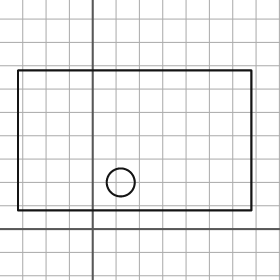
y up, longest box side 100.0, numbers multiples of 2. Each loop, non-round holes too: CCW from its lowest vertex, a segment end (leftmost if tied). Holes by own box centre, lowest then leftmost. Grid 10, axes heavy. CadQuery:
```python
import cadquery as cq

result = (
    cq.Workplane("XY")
    .moveTo(-32.0, 8.0)
    .lineTo(68.0, 8.0)
    .lineTo(68.0, 68.0)
    .lineTo(-32.0, 68.0)
    .close()
    .moveTo(12.0, 20.0)
    .circle(6.0)
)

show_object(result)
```